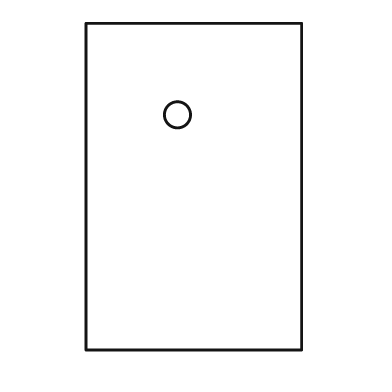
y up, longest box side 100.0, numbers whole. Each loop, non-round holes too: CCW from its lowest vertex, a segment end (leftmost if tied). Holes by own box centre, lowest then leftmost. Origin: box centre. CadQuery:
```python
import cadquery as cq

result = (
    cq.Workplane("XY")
    .moveTo(-33.0, -50.0)
    .lineTo(33.0, -50.0)
    .lineTo(33.0, 50.0)
    .lineTo(-33.0, 50.0)
    .close()
    .moveTo(-5.0, 22.0)
    .circle(4.0)
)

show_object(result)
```